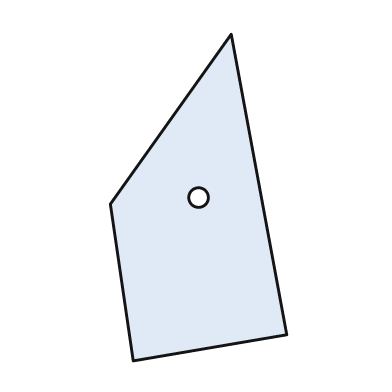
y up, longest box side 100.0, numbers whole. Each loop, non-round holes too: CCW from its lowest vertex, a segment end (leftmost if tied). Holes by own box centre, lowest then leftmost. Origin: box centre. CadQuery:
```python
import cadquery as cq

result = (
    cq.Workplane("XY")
    .moveTo(-20.0, -50.0)
    .lineTo(27.0, -42.0)
    .lineTo(10.0, 50.0)
    .lineTo(-27.0, -2.0)
    .close()
    .moveTo(0.0, 0.0)
    .circle(3.0)
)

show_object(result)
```